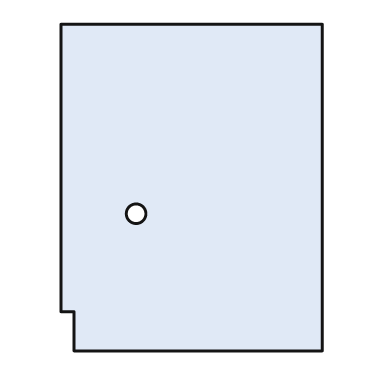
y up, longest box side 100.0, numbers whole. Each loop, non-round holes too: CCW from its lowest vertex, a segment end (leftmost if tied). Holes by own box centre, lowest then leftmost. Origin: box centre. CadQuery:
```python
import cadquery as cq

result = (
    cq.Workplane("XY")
    .moveTo(-36.0, -50.0)
    .lineTo(40.0, -50.0)
    .lineTo(40.0, 50.0)
    .lineTo(-40.0, 50.0)
    .lineTo(-40.0, -38.0)
    .lineTo(-36.0, -38.0)
    .close()
    .moveTo(-17.0, -8.0)
    .circle(3.0)
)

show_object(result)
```